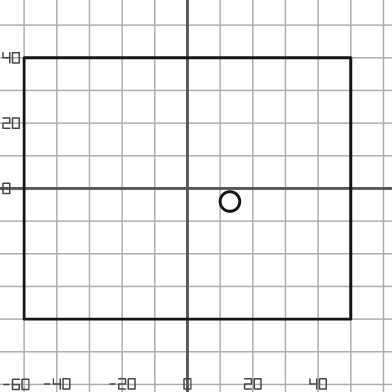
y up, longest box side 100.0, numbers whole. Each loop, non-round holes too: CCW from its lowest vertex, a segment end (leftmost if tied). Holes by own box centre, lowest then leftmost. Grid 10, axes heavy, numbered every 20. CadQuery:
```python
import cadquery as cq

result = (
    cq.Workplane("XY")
    .moveTo(-50.0, -40.0)
    .lineTo(50.0, -40.0)
    .lineTo(50.0, 40.0)
    .lineTo(-50.0, 40.0)
    .close()
    .moveTo(13.0, -4.0)
    .circle(3.0)
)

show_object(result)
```